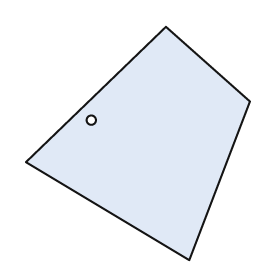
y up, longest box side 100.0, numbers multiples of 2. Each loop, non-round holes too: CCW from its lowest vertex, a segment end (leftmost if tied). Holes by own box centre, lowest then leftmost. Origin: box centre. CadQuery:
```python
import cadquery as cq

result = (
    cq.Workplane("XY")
    .moveTo(22.0, -50.0)
    .lineTo(48.0, 18.0)
    .lineTo(12.0, 50.0)
    .lineTo(-48.0, -8.0)
    .close()
    .moveTo(-20.0, 10.0)
    .circle(2.0)
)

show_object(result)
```